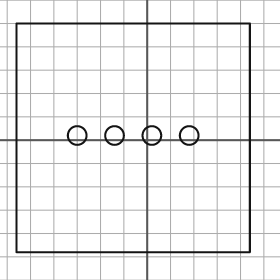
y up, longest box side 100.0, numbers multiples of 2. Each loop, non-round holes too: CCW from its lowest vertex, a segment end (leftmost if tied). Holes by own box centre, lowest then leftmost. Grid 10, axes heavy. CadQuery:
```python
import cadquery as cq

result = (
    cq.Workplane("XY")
    .moveTo(-56.0, -48.0)
    .lineTo(44.0, -48.0)
    .lineTo(44.0, 50.0)
    .lineTo(-56.0, 50.0)
    .close()
    .moveTo(-30.0, 2.0)
    .circle(4.0)
    .moveTo(-14.0, 2.0)
    .circle(4.0)
    .moveTo(2.0, 2.0)
    .circle(4.0)
    .moveTo(18.0, 2.0)
    .circle(4.0)
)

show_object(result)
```